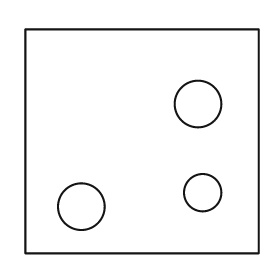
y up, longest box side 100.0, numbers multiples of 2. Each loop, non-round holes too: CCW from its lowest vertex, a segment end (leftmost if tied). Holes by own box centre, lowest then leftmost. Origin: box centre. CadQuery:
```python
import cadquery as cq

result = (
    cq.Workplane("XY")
    .moveTo(-50.0, -48.0)
    .lineTo(50.0, -48.0)
    .lineTo(50.0, 48.0)
    .lineTo(-50.0, 48.0)
    .close()
    .moveTo(-26.0, -28.0)
    .circle(10.0)
    .moveTo(26.0, -22.0)
    .circle(8.0)
    .moveTo(24.0, 16.0)
    .circle(10.0)
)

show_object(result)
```